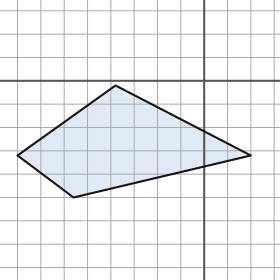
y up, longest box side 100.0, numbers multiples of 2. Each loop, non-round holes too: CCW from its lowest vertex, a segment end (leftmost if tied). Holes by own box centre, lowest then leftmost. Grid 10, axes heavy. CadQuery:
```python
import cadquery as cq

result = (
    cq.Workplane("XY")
    .moveTo(-56.0, -50.0)
    .lineTo(20.0, -32.0)
    .lineTo(-38.0, -2.0)
    .lineTo(-80.0, -32.0)
    .close()
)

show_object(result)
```